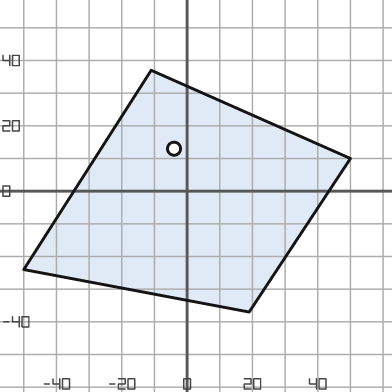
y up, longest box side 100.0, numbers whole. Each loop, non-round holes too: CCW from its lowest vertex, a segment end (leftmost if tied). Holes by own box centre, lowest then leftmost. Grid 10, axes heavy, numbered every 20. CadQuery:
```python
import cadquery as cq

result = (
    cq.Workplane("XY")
    .moveTo(19.0, -37.0)
    .lineTo(50.0, 10.0)
    .lineTo(-11.0, 37.0)
    .lineTo(-50.0, -24.0)
    .close()
    .moveTo(-4.0, 13.0)
    .circle(2.0)
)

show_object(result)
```